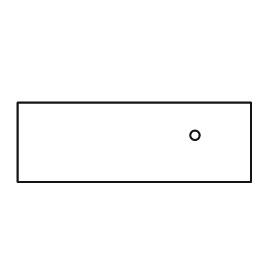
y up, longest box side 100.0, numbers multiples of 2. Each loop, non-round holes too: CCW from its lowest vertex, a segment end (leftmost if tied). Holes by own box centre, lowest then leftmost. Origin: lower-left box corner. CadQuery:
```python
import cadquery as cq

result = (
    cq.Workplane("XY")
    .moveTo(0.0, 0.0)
    .lineTo(100.0, 0.0)
    .lineTo(100.0, 34.0)
    .lineTo(0.0, 34.0)
    .close()
    .moveTo(76.0, 20.0)
    .circle(2.0)
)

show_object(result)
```